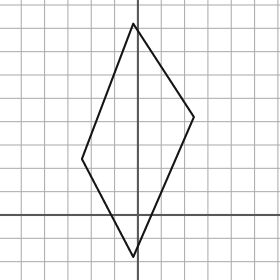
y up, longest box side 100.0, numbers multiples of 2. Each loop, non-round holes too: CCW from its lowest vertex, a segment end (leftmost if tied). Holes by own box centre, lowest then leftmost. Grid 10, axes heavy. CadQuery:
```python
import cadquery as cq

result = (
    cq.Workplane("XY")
    .moveTo(-2.0, -18.0)
    .lineTo(24.0, 42.0)
    .lineTo(-2.0, 82.0)
    .lineTo(-24.0, 24.0)
    .close()
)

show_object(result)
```